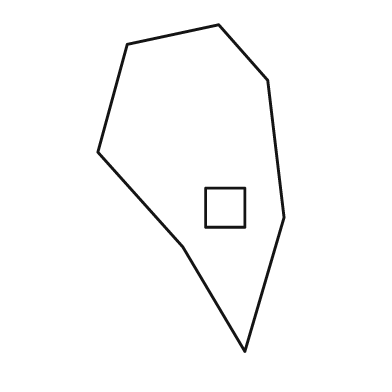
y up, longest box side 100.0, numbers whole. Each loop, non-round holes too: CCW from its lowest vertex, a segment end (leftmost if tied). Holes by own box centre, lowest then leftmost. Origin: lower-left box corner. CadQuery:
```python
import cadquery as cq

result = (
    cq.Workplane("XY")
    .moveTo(45.0, 0.0)
    .lineTo(57.0, 41.0)
    .lineTo(52.0, 83.0)
    .lineTo(37.0, 100.0)
    .lineTo(9.0, 94.0)
    .lineTo(0.0, 61.0)
    .lineTo(26.0, 32.0)
    .close()
    .moveTo(33.0, 38.0)
    .lineTo(45.0, 38.0)
    .lineTo(45.0, 50.0)
    .lineTo(33.0, 50.0)
    .close()
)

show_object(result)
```